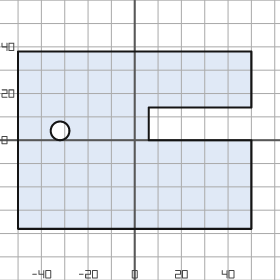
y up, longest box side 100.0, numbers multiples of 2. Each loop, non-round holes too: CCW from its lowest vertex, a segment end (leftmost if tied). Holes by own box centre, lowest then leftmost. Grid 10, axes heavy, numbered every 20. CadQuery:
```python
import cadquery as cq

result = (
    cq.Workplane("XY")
    .moveTo(-50.0, -38.0)
    .lineTo(50.0, -38.0)
    .lineTo(50.0, 0.0)
    .lineTo(6.0, 0.0)
    .lineTo(6.0, 14.0)
    .lineTo(50.0, 14.0)
    .lineTo(50.0, 38.0)
    .lineTo(-50.0, 38.0)
    .close()
    .moveTo(-32.0, 4.0)
    .circle(4.0)
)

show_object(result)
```